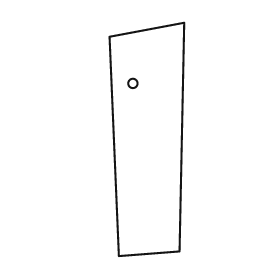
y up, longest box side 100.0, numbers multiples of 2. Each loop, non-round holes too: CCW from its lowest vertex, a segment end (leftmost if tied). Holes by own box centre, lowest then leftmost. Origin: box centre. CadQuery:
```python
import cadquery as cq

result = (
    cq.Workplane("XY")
    .moveTo(-12.0, -50.0)
    .lineTo(14.0, -48.0)
    .lineTo(16.0, 50.0)
    .lineTo(-16.0, 44.0)
    .close()
    .moveTo(-6.0, 24.0)
    .circle(2.0)
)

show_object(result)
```